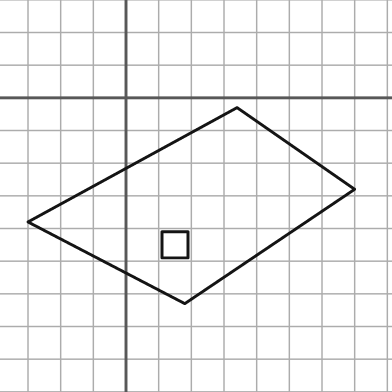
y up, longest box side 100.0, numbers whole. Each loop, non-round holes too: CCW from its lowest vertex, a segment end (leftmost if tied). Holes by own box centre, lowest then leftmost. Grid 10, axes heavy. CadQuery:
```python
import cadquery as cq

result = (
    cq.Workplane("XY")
    .moveTo(18.0, -63.0)
    .lineTo(70.0, -28.0)
    .lineTo(34.0, -3.0)
    .lineTo(-30.0, -38.0)
    .close()
    .moveTo(11.0, -49.0)
    .lineTo(19.0, -49.0)
    .lineTo(19.0, -41.0)
    .lineTo(11.0, -41.0)
    .close()
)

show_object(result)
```